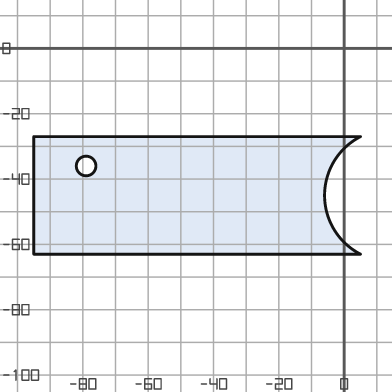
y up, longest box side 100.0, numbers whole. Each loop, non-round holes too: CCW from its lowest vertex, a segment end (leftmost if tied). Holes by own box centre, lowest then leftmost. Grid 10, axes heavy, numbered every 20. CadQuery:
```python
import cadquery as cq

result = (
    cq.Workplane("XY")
    .moveTo(-95.0, -63.0)
    .lineTo(5.0, -63.0)
    .threePointArc((-6.0, -45.0), (5.0, -27.0))
    .lineTo(-95.0, -27.0)
    .close()
    .moveTo(-79.0, -36.0)
    .circle(3.0)
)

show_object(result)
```